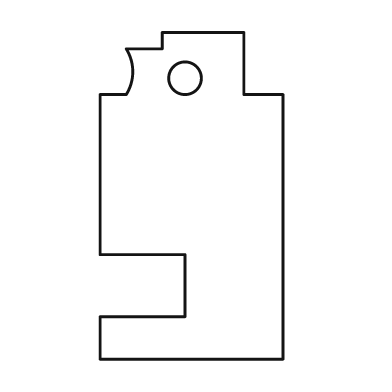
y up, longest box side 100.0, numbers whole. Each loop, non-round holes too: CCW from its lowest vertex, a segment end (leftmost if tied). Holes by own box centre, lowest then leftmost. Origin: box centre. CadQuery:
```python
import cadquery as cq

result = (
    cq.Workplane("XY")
    .moveTo(-28.0, -50.0)
    .lineTo(28.0, -50.0)
    .lineTo(28.0, 31.0)
    .lineTo(16.0, 31.0)
    .lineTo(16.0, 50.0)
    .lineTo(-9.0, 50.0)
    .lineTo(-9.0, 45.0)
    .lineTo(-20.0, 45.0)
    .threePointArc((-18.0, 38.0), (-20.0, 31.0))
    .lineTo(-28.0, 31.0)
    .lineTo(-28.0, -18.0)
    .lineTo(-2.0, -18.0)
    .lineTo(-2.0, -37.0)
    .lineTo(-28.0, -37.0)
    .close()
    .moveTo(-2.0, 36.0)
    .circle(5.0)
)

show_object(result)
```